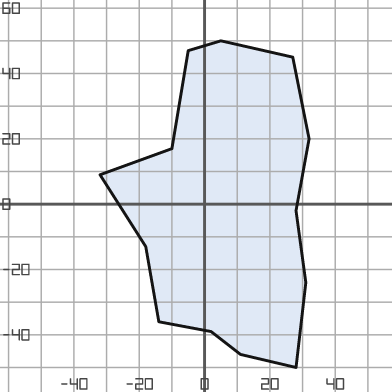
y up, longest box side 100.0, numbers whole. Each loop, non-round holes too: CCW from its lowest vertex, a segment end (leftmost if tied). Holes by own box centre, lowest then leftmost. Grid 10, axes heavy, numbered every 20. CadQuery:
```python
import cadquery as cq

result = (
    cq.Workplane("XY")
    .moveTo(28.0, -50.0)
    .lineTo(31.0, -24.0)
    .lineTo(28.0, -2.0)
    .lineTo(32.0, 20.0)
    .lineTo(27.0, 45.0)
    .lineTo(5.0, 50.0)
    .lineTo(-5.0, 47.0)
    .lineTo(-10.0, 17.0)
    .lineTo(-32.0, 9.0)
    .lineTo(-18.0, -13.0)
    .lineTo(-14.0, -36.0)
    .lineTo(2.0, -39.0)
    .lineTo(11.0, -46.0)
    .close()
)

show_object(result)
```